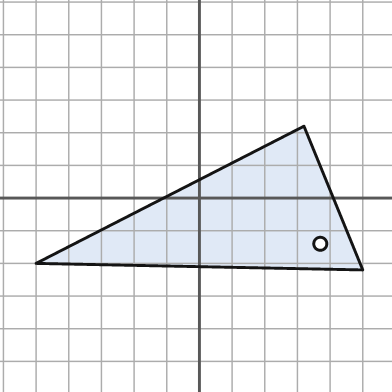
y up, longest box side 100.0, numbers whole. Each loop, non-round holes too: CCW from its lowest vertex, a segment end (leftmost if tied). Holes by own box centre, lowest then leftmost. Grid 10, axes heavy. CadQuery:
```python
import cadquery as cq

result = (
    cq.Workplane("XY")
    .moveTo(50.0, -22.0)
    .lineTo(32.0, 22.0)
    .lineTo(-50.0, -20.0)
    .close()
    .moveTo(37.0, -14.0)
    .circle(2.0)
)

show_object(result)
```